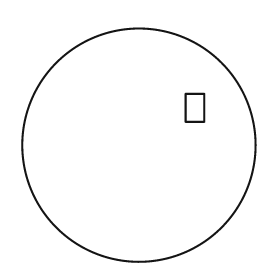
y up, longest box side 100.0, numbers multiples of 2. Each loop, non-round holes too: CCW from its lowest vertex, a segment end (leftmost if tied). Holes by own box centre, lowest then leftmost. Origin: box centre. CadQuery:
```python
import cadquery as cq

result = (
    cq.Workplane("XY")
    .moveTo(0.0, 0.0)
    .circle(50.0)
    .moveTo(20.0, 10.0)
    .lineTo(28.0, 10.0)
    .lineTo(28.0, 22.0)
    .lineTo(20.0, 22.0)
    .close()
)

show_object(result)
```